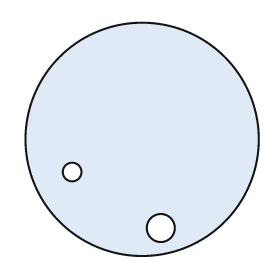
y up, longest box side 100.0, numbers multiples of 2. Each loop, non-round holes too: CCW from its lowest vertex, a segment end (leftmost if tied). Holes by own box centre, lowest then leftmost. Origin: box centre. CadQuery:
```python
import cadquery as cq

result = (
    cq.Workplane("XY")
    .moveTo(0.0, 0.0)
    .circle(50.0)
    .moveTo(8.0, -38.0)
    .circle(6.0)
    .moveTo(-30.0, -14.0)
    .circle(4.0)
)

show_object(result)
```